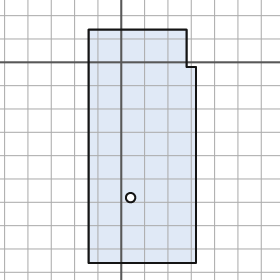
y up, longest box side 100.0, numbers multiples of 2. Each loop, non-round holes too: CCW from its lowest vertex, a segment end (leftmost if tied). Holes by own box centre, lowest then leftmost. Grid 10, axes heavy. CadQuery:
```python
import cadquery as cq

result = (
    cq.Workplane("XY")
    .moveTo(-14.0, -86.0)
    .lineTo(32.0, -86.0)
    .lineTo(32.0, -2.0)
    .lineTo(28.0, -2.0)
    .lineTo(28.0, 14.0)
    .lineTo(-14.0, 14.0)
    .close()
    .moveTo(4.0, -58.0)
    .circle(2.0)
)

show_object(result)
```